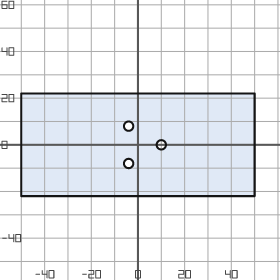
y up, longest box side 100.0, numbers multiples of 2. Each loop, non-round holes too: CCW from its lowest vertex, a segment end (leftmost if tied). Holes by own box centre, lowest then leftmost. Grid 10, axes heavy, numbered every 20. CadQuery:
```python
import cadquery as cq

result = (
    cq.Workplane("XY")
    .moveTo(-50.0, -22.0)
    .lineTo(50.0, -22.0)
    .lineTo(50.0, 22.0)
    .lineTo(-50.0, 22.0)
    .close()
    .moveTo(-4.0, -8.0)
    .circle(2.0)
    .moveTo(10.0, 0.0)
    .circle(2.0)
    .moveTo(-4.0, 8.0)
    .circle(2.0)
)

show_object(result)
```